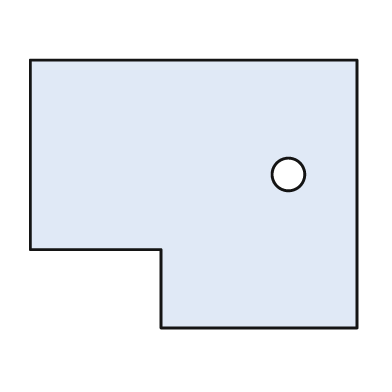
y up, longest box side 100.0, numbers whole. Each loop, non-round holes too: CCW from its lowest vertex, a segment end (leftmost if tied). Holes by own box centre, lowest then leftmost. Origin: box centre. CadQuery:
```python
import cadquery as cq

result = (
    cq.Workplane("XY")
    .moveTo(-10.0, -41.0)
    .lineTo(50.0, -41.0)
    .lineTo(50.0, 41.0)
    .lineTo(-50.0, 41.0)
    .lineTo(-50.0, -17.0)
    .lineTo(-10.0, -17.0)
    .close()
    .moveTo(29.0, 6.0)
    .circle(5.0)
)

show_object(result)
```